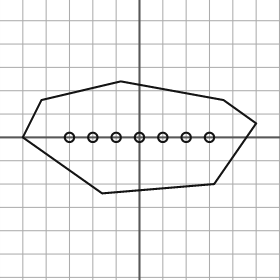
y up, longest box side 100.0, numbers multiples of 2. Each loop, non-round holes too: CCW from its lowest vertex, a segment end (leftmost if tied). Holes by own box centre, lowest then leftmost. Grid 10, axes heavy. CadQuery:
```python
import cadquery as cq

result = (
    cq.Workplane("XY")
    .moveTo(-16.0, -24.0)
    .lineTo(32.0, -20.0)
    .lineTo(50.0, 6.0)
    .lineTo(36.0, 16.0)
    .lineTo(-8.0, 24.0)
    .lineTo(-42.0, 16.0)
    .lineTo(-50.0, 0.0)
    .close()
    .moveTo(-30.0, 0.0)
    .circle(2.0)
    .moveTo(-20.0, 0.0)
    .circle(2.0)
    .moveTo(-10.0, 0.0)
    .circle(2.0)
    .moveTo(0.0, 0.0)
    .circle(2.0)
    .moveTo(10.0, 0.0)
    .circle(2.0)
    .moveTo(20.0, 0.0)
    .circle(2.0)
    .moveTo(30.0, 0.0)
    .circle(2.0)
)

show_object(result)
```